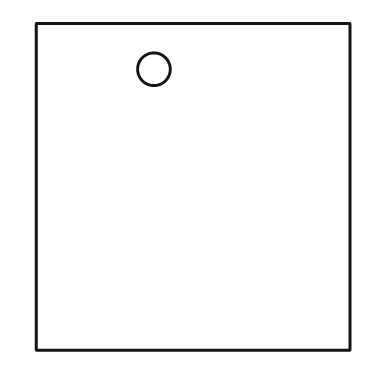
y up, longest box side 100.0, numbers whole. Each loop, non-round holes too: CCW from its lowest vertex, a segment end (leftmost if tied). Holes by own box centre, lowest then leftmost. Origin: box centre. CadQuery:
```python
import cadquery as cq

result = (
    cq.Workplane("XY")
    .moveTo(-48.0, -50.0)
    .lineTo(48.0, -50.0)
    .lineTo(48.0, 50.0)
    .lineTo(-48.0, 50.0)
    .close()
    .moveTo(-12.0, 36.0)
    .circle(5.0)
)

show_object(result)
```